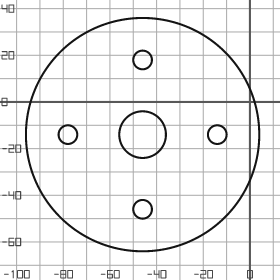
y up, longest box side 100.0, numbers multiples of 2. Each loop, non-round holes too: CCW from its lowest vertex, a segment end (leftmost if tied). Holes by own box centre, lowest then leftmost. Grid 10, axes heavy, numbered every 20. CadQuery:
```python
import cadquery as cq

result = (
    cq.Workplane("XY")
    .moveTo(-46.0, -14.0)
    .circle(50.0)
    .moveTo(-46.0, -46.0)
    .circle(4.0)
    .moveTo(-78.0, -14.0)
    .circle(4.0)
    .moveTo(-46.0, -14.0)
    .circle(10.0)
    .moveTo(-14.0, -14.0)
    .circle(4.0)
    .moveTo(-46.0, 18.0)
    .circle(4.0)
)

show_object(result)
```